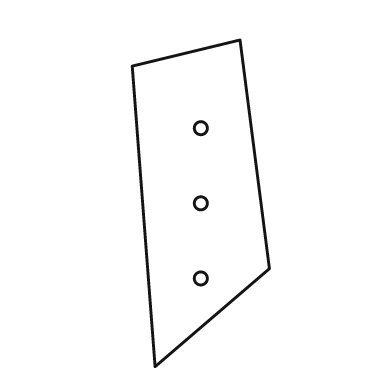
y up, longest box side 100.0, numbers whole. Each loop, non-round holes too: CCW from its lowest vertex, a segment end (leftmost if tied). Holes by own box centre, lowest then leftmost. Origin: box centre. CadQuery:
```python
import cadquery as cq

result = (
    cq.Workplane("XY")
    .moveTo(-14.0, -50.0)
    .lineTo(21.0, -20.0)
    .lineTo(12.0, 50.0)
    .lineTo(-21.0, 42.0)
    .close()
    .moveTo(0.0, -23.0)
    .circle(2.0)
    .moveTo(0.0, 0.0)
    .circle(2.0)
    .moveTo(0.0, 23.0)
    .circle(2.0)
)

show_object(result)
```